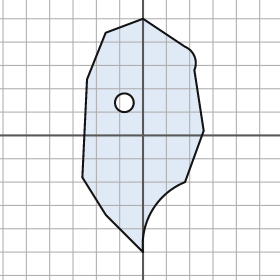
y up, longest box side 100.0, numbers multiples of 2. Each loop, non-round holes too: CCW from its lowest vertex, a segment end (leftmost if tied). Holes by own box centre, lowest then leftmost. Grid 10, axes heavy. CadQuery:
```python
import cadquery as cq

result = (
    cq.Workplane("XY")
    .moveTo(0.0, -50.0)
    .threePointArc((4.0, -32.0), (18.0, -20.0))
    .lineTo(26.0, 2.0)
    .lineTo(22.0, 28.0)
    .threePointArc((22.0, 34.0), (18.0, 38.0))
    .lineTo(0.0, 50.0)
    .lineTo(-16.0, 44.0)
    .lineTo(-24.0, 24.0)
    .lineTo(-26.0, -18.0)
    .lineTo(-16.0, -34.0)
    .close()
    .moveTo(-8.0, 14.0)
    .circle(4.0)
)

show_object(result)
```